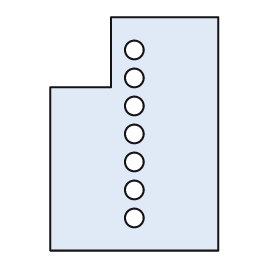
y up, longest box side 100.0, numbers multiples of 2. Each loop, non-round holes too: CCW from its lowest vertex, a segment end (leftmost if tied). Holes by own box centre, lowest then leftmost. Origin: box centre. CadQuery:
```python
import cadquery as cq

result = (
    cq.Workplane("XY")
    .moveTo(-36.0, -50.0)
    .lineTo(36.0, -50.0)
    .lineTo(36.0, 50.0)
    .lineTo(-10.0, 50.0)
    .lineTo(-10.0, 20.0)
    .lineTo(-36.0, 20.0)
    .close()
    .moveTo(0.0, -36.0)
    .circle(4.0)
    .moveTo(0.0, -24.0)
    .circle(4.0)
    .moveTo(0.0, -12.0)
    .circle(4.0)
    .moveTo(0.0, 0.0)
    .circle(4.0)
    .moveTo(0.0, 12.0)
    .circle(4.0)
    .moveTo(0.0, 24.0)
    .circle(4.0)
    .moveTo(0.0, 36.0)
    .circle(4.0)
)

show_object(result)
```